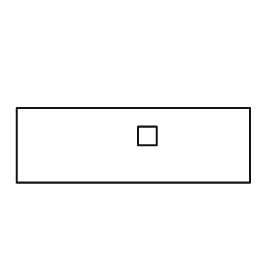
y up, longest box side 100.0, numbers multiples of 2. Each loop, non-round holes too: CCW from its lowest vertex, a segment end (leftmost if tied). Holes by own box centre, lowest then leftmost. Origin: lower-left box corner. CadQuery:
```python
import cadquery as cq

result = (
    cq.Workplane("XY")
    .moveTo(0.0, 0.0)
    .lineTo(100.0, 0.0)
    .lineTo(100.0, 32.0)
    .lineTo(0.0, 32.0)
    .close()
    .moveTo(52.0, 16.0)
    .lineTo(60.0, 16.0)
    .lineTo(60.0, 24.0)
    .lineTo(52.0, 24.0)
    .close()
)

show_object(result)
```